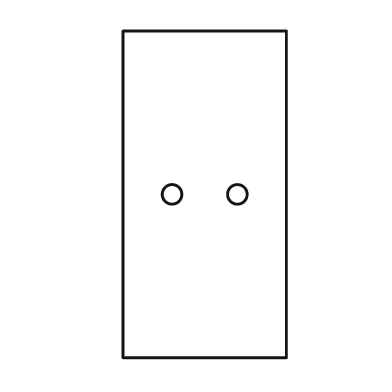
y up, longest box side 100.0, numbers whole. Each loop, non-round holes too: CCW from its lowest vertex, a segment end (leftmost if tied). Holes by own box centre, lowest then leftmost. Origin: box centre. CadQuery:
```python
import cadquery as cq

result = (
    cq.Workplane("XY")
    .moveTo(-25.0, -50.0)
    .lineTo(25.0, -50.0)
    .lineTo(25.0, 50.0)
    .lineTo(-25.0, 50.0)
    .close()
    .moveTo(-10.0, 0.0)
    .circle(3.0)
    .moveTo(10.0, 0.0)
    .circle(3.0)
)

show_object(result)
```